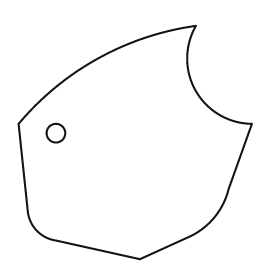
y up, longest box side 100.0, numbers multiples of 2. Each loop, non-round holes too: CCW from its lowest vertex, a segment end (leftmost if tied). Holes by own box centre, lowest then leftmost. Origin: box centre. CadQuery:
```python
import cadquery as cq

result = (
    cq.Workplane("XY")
    .moveTo(2.0, -50.0)
    .lineTo(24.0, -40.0)
    .threePointArc((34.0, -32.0), (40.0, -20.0))
    .lineTo(50.0, 8.0)
    .threePointArc((26.0, 22.0), (26.0, 50.0))
    .threePointArc((-16.0, 36.0), (-50.0, 8.0))
    .lineTo(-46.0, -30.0)
    .threePointArc((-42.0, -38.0), (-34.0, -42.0))
    .close()
    .moveTo(-34.0, 4.0)
    .circle(4.0)
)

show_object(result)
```